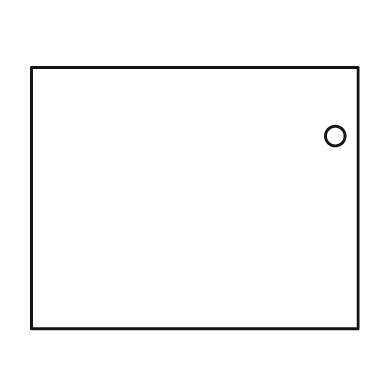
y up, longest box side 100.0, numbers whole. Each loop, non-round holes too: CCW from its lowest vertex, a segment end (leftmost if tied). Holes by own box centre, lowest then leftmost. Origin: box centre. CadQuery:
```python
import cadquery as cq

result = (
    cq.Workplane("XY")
    .moveTo(-50.0, -40.0)
    .lineTo(50.0, -40.0)
    .lineTo(50.0, 40.0)
    .lineTo(-50.0, 40.0)
    .close()
    .moveTo(43.0, 19.0)
    .circle(3.0)
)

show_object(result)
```